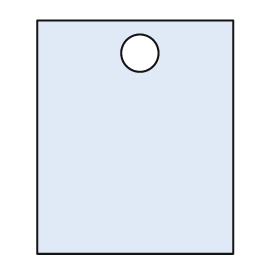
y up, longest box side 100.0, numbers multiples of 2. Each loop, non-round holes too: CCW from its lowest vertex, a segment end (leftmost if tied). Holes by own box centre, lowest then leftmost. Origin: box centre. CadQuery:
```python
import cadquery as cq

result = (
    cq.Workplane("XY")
    .moveTo(-42.0, -50.0)
    .lineTo(42.0, -50.0)
    .lineTo(42.0, 50.0)
    .lineTo(-42.0, 50.0)
    .close()
    .moveTo(2.0, 36.0)
    .circle(8.0)
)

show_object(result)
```